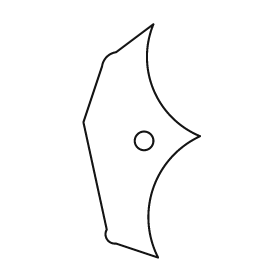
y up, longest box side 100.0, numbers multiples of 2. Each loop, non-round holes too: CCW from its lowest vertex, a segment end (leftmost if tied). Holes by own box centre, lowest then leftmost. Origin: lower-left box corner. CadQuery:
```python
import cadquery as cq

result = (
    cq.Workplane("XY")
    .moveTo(32.0, 0.0)
    .threePointArc((30.0, 30.0), (50.0, 52.0))
    .threePointArc((30.0, 72.0), (30.0, 100.0))
    .lineTo(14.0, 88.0)
    .threePointArc((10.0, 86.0), (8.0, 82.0))
    .lineTo(0.0, 58.0)
    .lineTo(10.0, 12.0)
    .threePointArc((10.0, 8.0), (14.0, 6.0))
    .close()
    .moveTo(26.0, 50.0)
    .circle(4.0)
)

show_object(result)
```